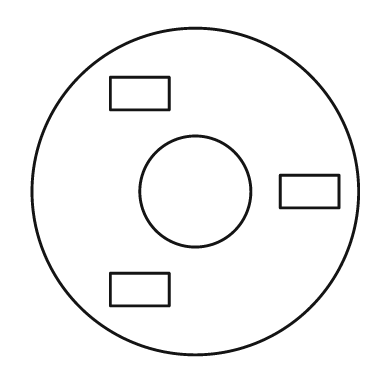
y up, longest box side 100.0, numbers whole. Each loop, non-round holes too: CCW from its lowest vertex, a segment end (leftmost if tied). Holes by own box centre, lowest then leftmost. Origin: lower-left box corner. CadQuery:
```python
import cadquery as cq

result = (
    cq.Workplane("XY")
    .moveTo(50.0, 50.0)
    .circle(50.0)
    .moveTo(24.0, 15.0)
    .lineTo(42.0, 15.0)
    .lineTo(42.0, 25.0)
    .lineTo(24.0, 25.0)
    .close()
    .moveTo(50.0, 50.0)
    .circle(17.0)
    .moveTo(76.0, 45.0)
    .lineTo(94.0, 45.0)
    .lineTo(94.0, 55.0)
    .lineTo(76.0, 55.0)
    .close()
    .moveTo(24.0, 75.0)
    .lineTo(42.0, 75.0)
    .lineTo(42.0, 85.0)
    .lineTo(24.0, 85.0)
    .close()
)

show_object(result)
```